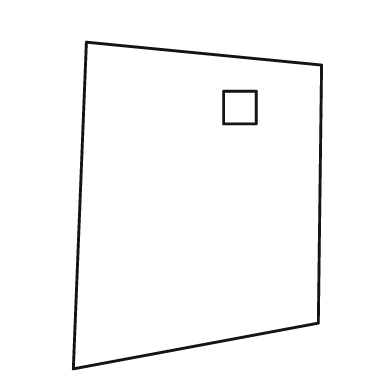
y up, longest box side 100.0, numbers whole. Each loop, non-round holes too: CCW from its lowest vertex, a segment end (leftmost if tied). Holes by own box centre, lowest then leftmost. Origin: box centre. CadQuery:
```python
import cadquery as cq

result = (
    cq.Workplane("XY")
    .moveTo(-38.0, -50.0)
    .lineTo(37.0, -36.0)
    .lineTo(38.0, 43.0)
    .lineTo(-34.0, 50.0)
    .close()
    .moveTo(8.0, 25.0)
    .lineTo(18.0, 25.0)
    .lineTo(18.0, 35.0)
    .lineTo(8.0, 35.0)
    .close()
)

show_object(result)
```